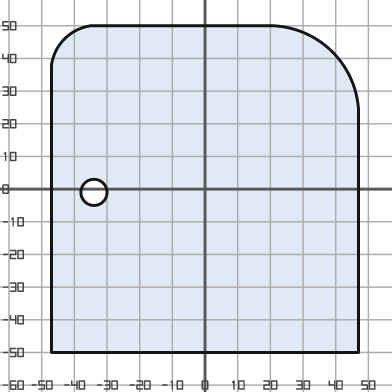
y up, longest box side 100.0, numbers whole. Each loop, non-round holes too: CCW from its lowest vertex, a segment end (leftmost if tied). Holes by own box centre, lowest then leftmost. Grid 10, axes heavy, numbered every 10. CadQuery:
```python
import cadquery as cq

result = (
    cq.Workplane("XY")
    .moveTo(-47.0, -50.0)
    .lineTo(47.0, -50.0)
    .lineTo(47.0, 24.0)
    .threePointArc((39.0, 42.0), (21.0, 50.0))
    .lineTo(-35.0, 50.0)
    .threePointArc((-43.0, 46.0), (-47.0, 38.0))
    .close()
    .moveTo(-34.0, -1.0)
    .circle(4.0)
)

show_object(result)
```